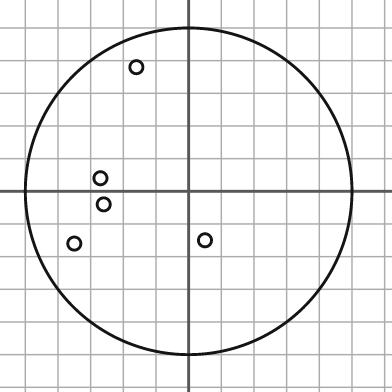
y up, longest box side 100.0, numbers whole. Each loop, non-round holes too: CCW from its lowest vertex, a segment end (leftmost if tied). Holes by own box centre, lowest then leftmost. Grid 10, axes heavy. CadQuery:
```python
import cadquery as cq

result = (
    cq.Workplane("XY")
    .moveTo(0.0, 0.0)
    .circle(50.0)
    .moveTo(-35.0, -16.0)
    .circle(2.0)
    .moveTo(5.0, -15.0)
    .circle(2.0)
    .moveTo(-26.0, -4.0)
    .circle(2.0)
    .moveTo(-27.0, 4.0)
    .circle(2.0)
    .moveTo(-16.0, 38.0)
    .circle(2.0)
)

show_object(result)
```